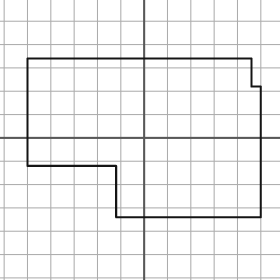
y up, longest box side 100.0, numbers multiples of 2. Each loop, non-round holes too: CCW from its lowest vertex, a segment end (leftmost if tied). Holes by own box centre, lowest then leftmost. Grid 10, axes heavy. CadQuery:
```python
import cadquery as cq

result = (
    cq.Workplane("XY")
    .moveTo(-12.0, -34.0)
    .lineTo(50.0, -34.0)
    .lineTo(50.0, 22.0)
    .lineTo(46.0, 22.0)
    .lineTo(46.0, 34.0)
    .lineTo(-50.0, 34.0)
    .lineTo(-50.0, -12.0)
    .lineTo(-12.0, -12.0)
    .close()
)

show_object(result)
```